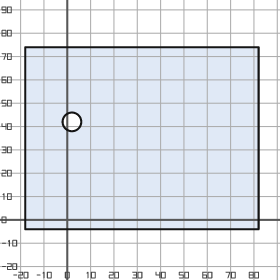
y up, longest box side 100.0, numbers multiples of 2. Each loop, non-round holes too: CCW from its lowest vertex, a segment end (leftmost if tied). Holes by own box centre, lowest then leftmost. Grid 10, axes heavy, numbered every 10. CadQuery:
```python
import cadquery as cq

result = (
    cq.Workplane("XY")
    .moveTo(-18.0, -4.0)
    .lineTo(82.0, -4.0)
    .lineTo(82.0, 74.0)
    .lineTo(-18.0, 74.0)
    .close()
    .moveTo(2.0, 42.0)
    .circle(4.0)
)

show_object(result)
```